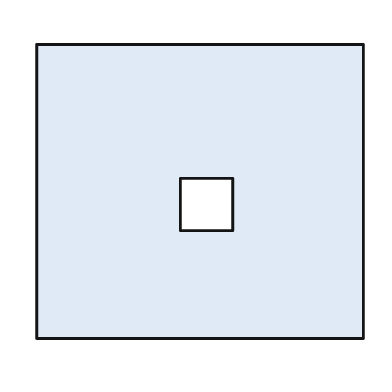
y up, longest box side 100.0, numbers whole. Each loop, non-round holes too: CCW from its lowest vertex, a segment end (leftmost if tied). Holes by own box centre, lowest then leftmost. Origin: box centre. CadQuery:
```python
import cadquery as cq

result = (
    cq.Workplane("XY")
    .moveTo(-50.0, -45.0)
    .lineTo(50.0, -45.0)
    .lineTo(50.0, 45.0)
    .lineTo(-50.0, 45.0)
    .close()
    .moveTo(-6.0, -12.0)
    .lineTo(10.0, -12.0)
    .lineTo(10.0, 4.0)
    .lineTo(-6.0, 4.0)
    .close()
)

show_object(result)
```